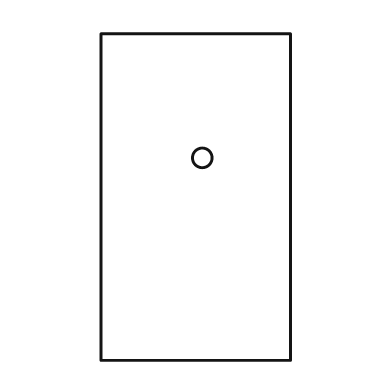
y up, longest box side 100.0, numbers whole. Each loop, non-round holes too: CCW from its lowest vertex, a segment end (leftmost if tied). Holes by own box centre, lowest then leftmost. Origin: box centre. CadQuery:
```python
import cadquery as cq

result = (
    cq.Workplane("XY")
    .moveTo(-29.0, -50.0)
    .lineTo(29.0, -50.0)
    .lineTo(29.0, 50.0)
    .lineTo(-29.0, 50.0)
    .close()
    .moveTo(2.0, 12.0)
    .circle(3.0)
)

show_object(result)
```